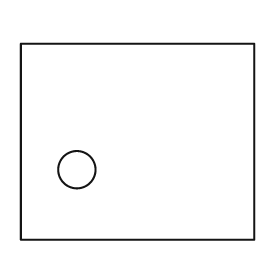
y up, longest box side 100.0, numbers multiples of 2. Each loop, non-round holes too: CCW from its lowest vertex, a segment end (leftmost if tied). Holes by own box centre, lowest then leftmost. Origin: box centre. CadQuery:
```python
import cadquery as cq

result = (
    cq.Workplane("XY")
    .moveTo(-50.0, -42.0)
    .lineTo(50.0, -42.0)
    .lineTo(50.0, 42.0)
    .lineTo(-50.0, 42.0)
    .close()
    .moveTo(-26.0, -12.0)
    .circle(8.0)
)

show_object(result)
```